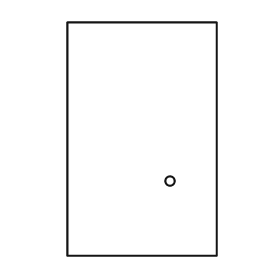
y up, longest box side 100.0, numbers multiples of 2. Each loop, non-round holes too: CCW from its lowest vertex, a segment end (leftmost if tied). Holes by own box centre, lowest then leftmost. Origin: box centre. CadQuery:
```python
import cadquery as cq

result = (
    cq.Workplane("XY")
    .moveTo(-32.0, -50.0)
    .lineTo(32.0, -50.0)
    .lineTo(32.0, 50.0)
    .lineTo(-32.0, 50.0)
    .close()
    .moveTo(12.0, -18.0)
    .circle(2.0)
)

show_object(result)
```